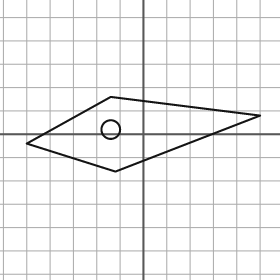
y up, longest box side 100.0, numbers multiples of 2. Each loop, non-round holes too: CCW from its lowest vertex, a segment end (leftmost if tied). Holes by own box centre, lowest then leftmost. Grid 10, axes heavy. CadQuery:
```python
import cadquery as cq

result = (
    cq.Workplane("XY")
    .moveTo(-12.0, -16.0)
    .lineTo(50.0, 8.0)
    .lineTo(-14.0, 16.0)
    .lineTo(-50.0, -4.0)
    .close()
    .moveTo(-14.0, 2.0)
    .circle(4.0)
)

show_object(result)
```